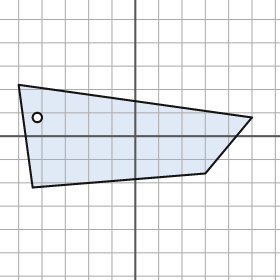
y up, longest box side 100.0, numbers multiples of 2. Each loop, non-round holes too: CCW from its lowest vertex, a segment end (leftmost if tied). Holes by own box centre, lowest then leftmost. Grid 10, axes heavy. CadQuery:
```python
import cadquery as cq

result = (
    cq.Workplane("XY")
    .moveTo(-44.0, -22.0)
    .lineTo(30.0, -16.0)
    .lineTo(50.0, 8.0)
    .lineTo(-50.0, 22.0)
    .close()
    .moveTo(-42.0, 8.0)
    .circle(2.0)
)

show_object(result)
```